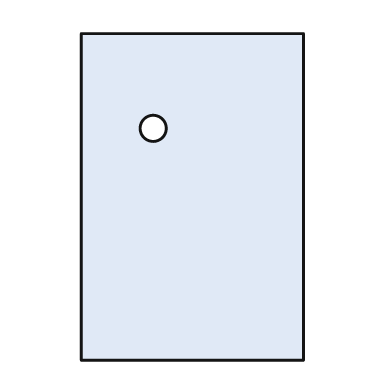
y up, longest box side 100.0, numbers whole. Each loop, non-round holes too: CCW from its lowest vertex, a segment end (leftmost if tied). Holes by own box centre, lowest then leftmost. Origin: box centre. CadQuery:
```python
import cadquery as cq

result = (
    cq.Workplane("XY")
    .moveTo(-34.0, -50.0)
    .lineTo(34.0, -50.0)
    .lineTo(34.0, 50.0)
    .lineTo(-34.0, 50.0)
    .close()
    .moveTo(-12.0, 21.0)
    .circle(4.0)
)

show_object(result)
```